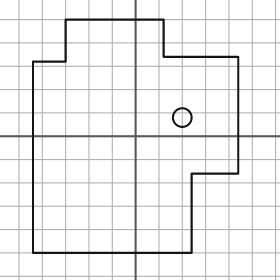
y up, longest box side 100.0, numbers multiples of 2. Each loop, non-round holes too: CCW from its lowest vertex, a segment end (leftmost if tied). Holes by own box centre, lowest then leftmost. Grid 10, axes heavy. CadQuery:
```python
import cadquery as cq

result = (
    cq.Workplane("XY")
    .moveTo(-44.0, -50.0)
    .lineTo(24.0, -50.0)
    .lineTo(24.0, -16.0)
    .lineTo(44.0, -16.0)
    .lineTo(44.0, 34.0)
    .lineTo(12.0, 34.0)
    .lineTo(12.0, 50.0)
    .lineTo(-30.0, 50.0)
    .lineTo(-30.0, 32.0)
    .lineTo(-44.0, 32.0)
    .close()
    .moveTo(20.0, 8.0)
    .circle(4.0)
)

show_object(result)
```